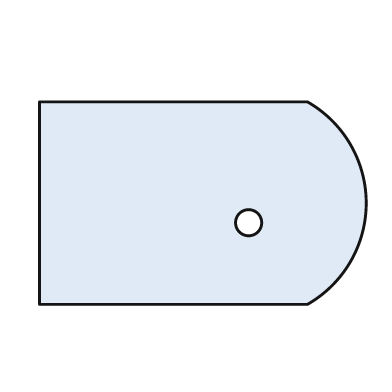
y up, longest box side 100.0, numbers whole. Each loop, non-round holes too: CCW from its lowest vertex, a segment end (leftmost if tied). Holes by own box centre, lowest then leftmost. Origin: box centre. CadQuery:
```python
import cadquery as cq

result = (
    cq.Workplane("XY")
    .moveTo(-50.0, -31.0)
    .lineTo(32.0, -31.0)
    .threePointArc((50.0, 0.0), (32.0, 31.0))
    .lineTo(-50.0, 31.0)
    .close()
    .moveTo(14.0, -6.0)
    .circle(4.0)
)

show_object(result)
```